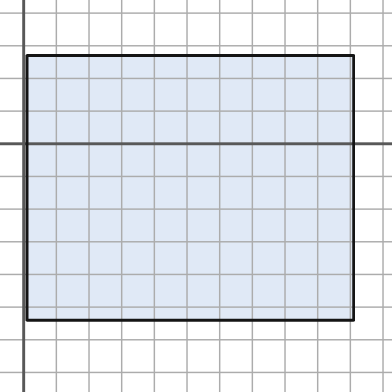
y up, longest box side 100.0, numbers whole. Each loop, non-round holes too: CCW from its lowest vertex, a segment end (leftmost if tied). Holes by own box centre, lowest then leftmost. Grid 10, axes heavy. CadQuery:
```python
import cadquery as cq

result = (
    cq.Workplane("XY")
    .moveTo(1.0, -54.0)
    .lineTo(101.0, -54.0)
    .lineTo(101.0, 27.0)
    .lineTo(1.0, 27.0)
    .close()
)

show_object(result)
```